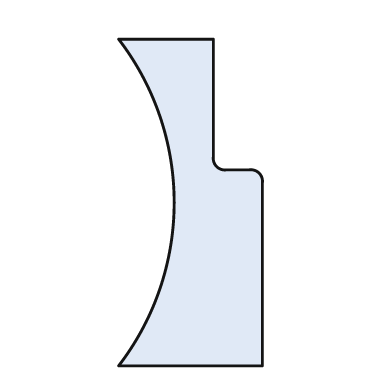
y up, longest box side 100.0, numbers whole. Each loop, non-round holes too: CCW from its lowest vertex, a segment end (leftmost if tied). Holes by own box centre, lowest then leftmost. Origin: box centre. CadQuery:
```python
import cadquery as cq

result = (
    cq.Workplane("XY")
    .moveTo(-22.0, -50.0)
    .lineTo(22.0, -50.0)
    .lineTo(22.0, 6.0)
    .threePointArc((21.0, 9.0), (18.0, 10.0))
    .lineTo(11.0, 10.0)
    .threePointArc((8.0, 11.0), (7.0, 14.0))
    .lineTo(7.0, 50.0)
    .lineTo(-22.0, 50.0)
    .threePointArc((-5.0, 0.0), (-22.0, -50.0))
    .close()
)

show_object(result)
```